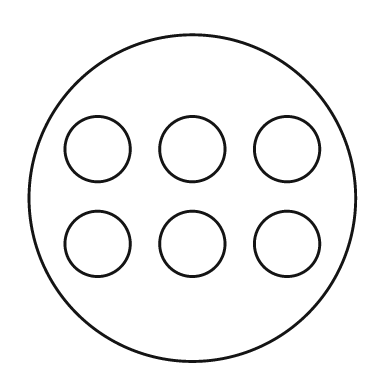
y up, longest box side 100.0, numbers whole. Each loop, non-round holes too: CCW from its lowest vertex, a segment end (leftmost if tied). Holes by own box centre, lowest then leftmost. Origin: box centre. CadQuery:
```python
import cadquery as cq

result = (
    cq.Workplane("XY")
    .moveTo(0.0, 0.0)
    .circle(50.0)
    .moveTo(-29.0, -14.0)
    .circle(10.0)
    .moveTo(0.0, -14.0)
    .circle(10.0)
    .moveTo(29.0, -14.0)
    .circle(10.0)
    .moveTo(-29.0, 15.0)
    .circle(10.0)
    .moveTo(0.0, 15.0)
    .circle(10.0)
    .moveTo(29.0, 15.0)
    .circle(10.0)
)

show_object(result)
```